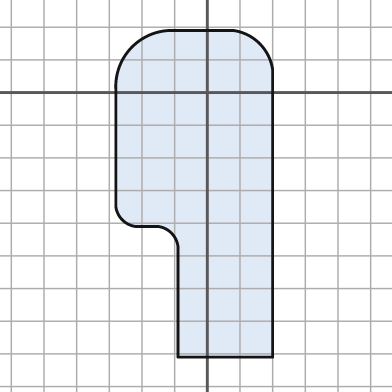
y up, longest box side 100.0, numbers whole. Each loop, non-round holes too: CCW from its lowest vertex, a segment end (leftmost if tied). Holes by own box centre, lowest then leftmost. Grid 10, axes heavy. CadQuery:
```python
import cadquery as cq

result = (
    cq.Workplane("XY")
    .moveTo(-9.0, -81.0)
    .lineTo(20.0, -81.0)
    .lineTo(20.0, 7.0)
    .threePointArc((16.0, 15.0), (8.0, 19.0))
    .lineTo(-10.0, 19.0)
    .threePointArc((-23.0, 14.0), (-28.0, 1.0))
    .lineTo(-28.0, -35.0)
    .threePointArc((-26.0, -39.0), (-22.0, -41.0))
    .lineTo(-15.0, -41.0)
    .threePointArc((-11.0, -43.0), (-9.0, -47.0))
    .close()
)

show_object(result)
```